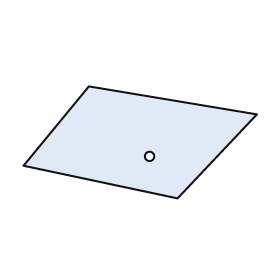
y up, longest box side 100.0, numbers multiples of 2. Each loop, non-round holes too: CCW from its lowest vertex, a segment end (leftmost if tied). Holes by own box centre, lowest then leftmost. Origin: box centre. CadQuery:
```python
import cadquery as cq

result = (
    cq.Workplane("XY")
    .moveTo(16.0, -24.0)
    .lineTo(50.0, 12.0)
    .lineTo(-22.0, 24.0)
    .lineTo(-50.0, -10.0)
    .close()
    .moveTo(4.0, -6.0)
    .circle(2.0)
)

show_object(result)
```